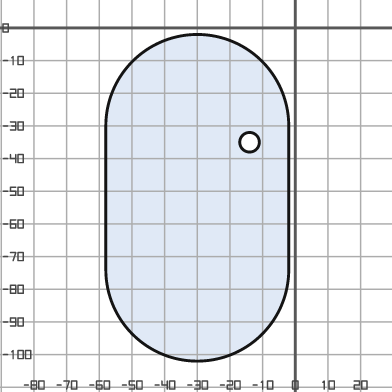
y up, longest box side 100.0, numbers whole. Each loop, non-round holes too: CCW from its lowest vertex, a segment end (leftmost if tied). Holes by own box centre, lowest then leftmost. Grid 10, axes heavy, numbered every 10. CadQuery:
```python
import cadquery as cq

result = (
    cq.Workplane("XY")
    .moveTo(-58.0, -74.0)
    .threePointArc((-30.0, -102.0), (-2.0, -74.0))
    .lineTo(-2.0, -30.0)
    .threePointArc((-30.0, -2.0), (-58.0, -30.0))
    .close()
    .moveTo(-14.0, -35.0)
    .circle(3.0)
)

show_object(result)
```